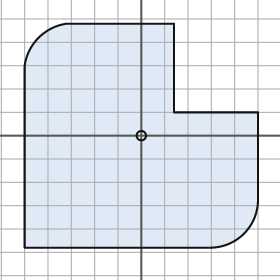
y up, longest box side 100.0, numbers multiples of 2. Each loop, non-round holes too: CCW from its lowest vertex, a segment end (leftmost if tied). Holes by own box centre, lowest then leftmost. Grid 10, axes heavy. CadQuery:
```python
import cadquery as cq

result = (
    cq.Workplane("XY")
    .moveTo(-50.0, -48.0)
    .lineTo(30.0, -48.0)
    .threePointArc((44.0, -42.0), (50.0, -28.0))
    .lineTo(50.0, 10.0)
    .lineTo(14.0, 10.0)
    .lineTo(14.0, 48.0)
    .lineTo(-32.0, 48.0)
    .threePointArc((-44.0, 42.0), (-50.0, 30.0))
    .close()
    .moveTo(0.0, 0.0)
    .circle(2.0)
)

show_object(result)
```